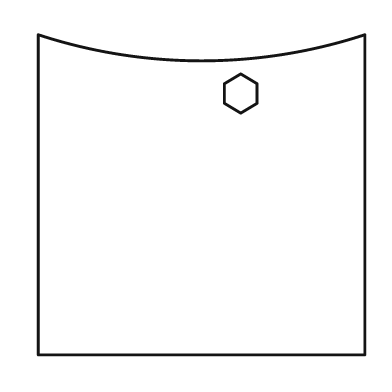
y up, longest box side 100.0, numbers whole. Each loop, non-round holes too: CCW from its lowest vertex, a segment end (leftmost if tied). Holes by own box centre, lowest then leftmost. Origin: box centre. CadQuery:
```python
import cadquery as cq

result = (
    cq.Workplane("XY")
    .moveTo(-50.0, -49.0)
    .lineTo(50.0, -49.0)
    .lineTo(50.0, 49.0)
    .threePointArc((0.0, 41.0), (-50.0, 49.0))
    .close()
    .moveTo(12.0, 25.0)
    .lineTo(17.0, 28.0)
    .lineTo(17.0, 34.0)
    .lineTo(12.0, 37.0)
    .lineTo(7.0, 34.0)
    .lineTo(7.0, 28.0)
    .close()
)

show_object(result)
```